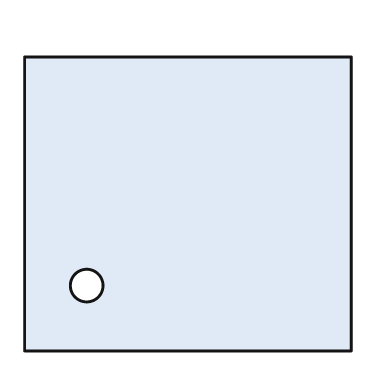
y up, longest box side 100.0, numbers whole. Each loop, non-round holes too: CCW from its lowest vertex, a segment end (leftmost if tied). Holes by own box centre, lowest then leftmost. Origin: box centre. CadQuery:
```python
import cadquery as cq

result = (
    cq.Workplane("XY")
    .moveTo(-50.0, -45.0)
    .lineTo(50.0, -45.0)
    .lineTo(50.0, 45.0)
    .lineTo(-50.0, 45.0)
    .close()
    .moveTo(-31.0, -25.0)
    .circle(5.0)
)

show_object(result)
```